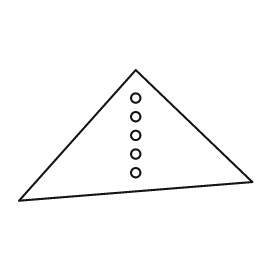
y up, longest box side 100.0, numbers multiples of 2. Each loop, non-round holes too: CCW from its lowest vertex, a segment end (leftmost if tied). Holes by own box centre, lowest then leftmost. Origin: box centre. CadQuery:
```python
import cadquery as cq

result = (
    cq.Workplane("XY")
    .moveTo(-50.0, -28.0)
    .lineTo(50.0, -20.0)
    .lineTo(0.0, 28.0)
    .close()
    .moveTo(0.0, -16.0)
    .circle(2.0)
    .moveTo(0.0, -8.0)
    .circle(2.0)
    .moveTo(0.0, 0.0)
    .circle(2.0)
    .moveTo(0.0, 8.0)
    .circle(2.0)
    .moveTo(0.0, 16.0)
    .circle(2.0)
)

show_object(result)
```